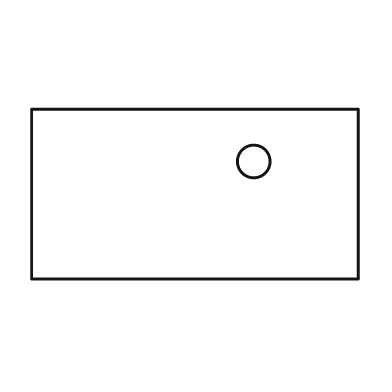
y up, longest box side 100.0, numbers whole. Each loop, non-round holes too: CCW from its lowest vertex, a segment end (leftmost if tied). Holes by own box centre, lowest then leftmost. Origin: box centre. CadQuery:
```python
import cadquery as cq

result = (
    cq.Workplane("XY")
    .moveTo(-50.0, -26.0)
    .lineTo(50.0, -26.0)
    .lineTo(50.0, 26.0)
    .lineTo(-50.0, 26.0)
    .close()
    .moveTo(18.0, 10.0)
    .circle(5.0)
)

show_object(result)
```